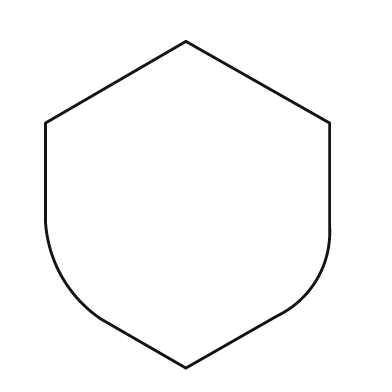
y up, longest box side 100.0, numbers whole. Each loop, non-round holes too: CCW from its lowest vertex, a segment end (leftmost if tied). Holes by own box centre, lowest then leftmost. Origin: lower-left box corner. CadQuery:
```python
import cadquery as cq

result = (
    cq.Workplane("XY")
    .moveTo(43.0, 0.0)
    .lineTo(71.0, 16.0)
    .threePointArc((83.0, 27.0), (87.0, 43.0))
    .lineTo(87.0, 75.0)
    .lineTo(43.0, 100.0)
    .lineTo(0.0, 75.0)
    .lineTo(0.0, 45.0)
    .threePointArc((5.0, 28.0), (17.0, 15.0))
    .close()
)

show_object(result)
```